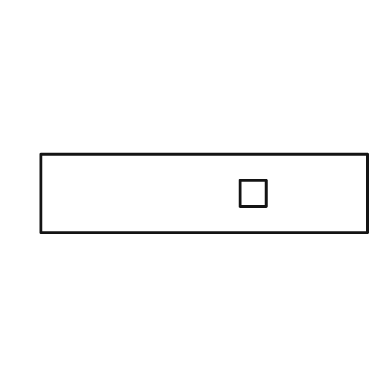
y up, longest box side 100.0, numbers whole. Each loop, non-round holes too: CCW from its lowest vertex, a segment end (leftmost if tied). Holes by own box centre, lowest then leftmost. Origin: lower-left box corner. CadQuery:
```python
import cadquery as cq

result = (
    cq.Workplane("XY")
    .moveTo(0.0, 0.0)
    .lineTo(100.0, 0.0)
    .lineTo(100.0, 24.0)
    .lineTo(0.0, 24.0)
    .close()
    .moveTo(61.0, 8.0)
    .lineTo(69.0, 8.0)
    .lineTo(69.0, 16.0)
    .lineTo(61.0, 16.0)
    .close()
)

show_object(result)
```